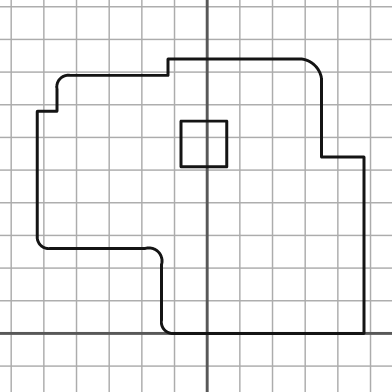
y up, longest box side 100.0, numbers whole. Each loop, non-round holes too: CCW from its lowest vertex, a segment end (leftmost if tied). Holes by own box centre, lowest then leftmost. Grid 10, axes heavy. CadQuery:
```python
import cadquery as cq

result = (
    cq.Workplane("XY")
    .moveTo(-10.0, 0.0)
    .lineTo(48.0, 0.0)
    .lineTo(48.0, 54.0)
    .lineTo(35.0, 54.0)
    .lineTo(35.0, 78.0)
    .threePointArc((33.0, 82.0), (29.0, 84.0))
    .lineTo(-12.0, 84.0)
    .lineTo(-12.0, 79.0)
    .lineTo(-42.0, 79.0)
    .threePointArc((-45.0, 78.0), (-46.0, 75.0))
    .lineTo(-46.0, 68.0)
    .lineTo(-52.0, 68.0)
    .lineTo(-52.0, 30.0)
    .threePointArc((-51.0, 27.0), (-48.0, 26.0))
    .lineTo(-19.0, 26.0)
    .threePointArc((-15.0, 25.0), (-14.0, 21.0))
    .lineTo(-14.0, 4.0)
    .threePointArc((-13.0, 1.0), (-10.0, 0.0))
    .close()
    .moveTo(-8.0, 51.0)
    .lineTo(6.0, 51.0)
    .lineTo(6.0, 65.0)
    .lineTo(-8.0, 65.0)
    .close()
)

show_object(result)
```